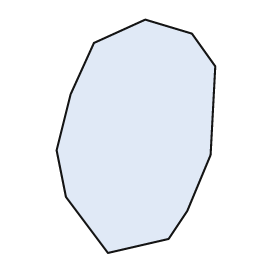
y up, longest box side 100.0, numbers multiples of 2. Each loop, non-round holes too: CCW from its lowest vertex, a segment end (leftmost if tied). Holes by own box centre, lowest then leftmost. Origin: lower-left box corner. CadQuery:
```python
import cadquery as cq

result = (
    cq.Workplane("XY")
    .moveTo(22.0, 0.0)
    .lineTo(48.0, 6.0)
    .lineTo(56.0, 18.0)
    .lineTo(66.0, 42.0)
    .lineTo(68.0, 80.0)
    .lineTo(58.0, 94.0)
    .lineTo(38.0, 100.0)
    .lineTo(16.0, 90.0)
    .lineTo(6.0, 68.0)
    .lineTo(0.0, 44.0)
    .lineTo(4.0, 24.0)
    .close()
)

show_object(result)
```